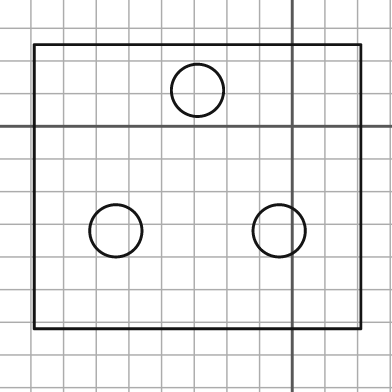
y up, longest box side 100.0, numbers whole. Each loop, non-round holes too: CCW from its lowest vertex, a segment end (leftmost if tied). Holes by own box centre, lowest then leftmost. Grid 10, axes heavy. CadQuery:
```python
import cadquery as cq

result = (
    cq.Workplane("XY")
    .moveTo(-79.0, -62.0)
    .lineTo(21.0, -62.0)
    .lineTo(21.0, 25.0)
    .lineTo(-79.0, 25.0)
    .close()
    .moveTo(-54.0, -32.0)
    .circle(8.0)
    .moveTo(-4.0, -32.0)
    .circle(8.0)
    .moveTo(-29.0, 11.0)
    .circle(8.0)
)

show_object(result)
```